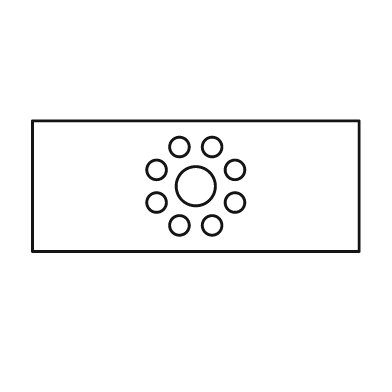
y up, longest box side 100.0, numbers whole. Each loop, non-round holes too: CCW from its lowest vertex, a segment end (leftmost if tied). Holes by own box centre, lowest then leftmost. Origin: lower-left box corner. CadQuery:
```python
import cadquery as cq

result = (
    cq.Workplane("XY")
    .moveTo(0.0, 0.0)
    .lineTo(100.0, 0.0)
    .lineTo(100.0, 40.0)
    .lineTo(0.0, 40.0)
    .close()
    .moveTo(45.0, 8.0)
    .circle(3.0)
    .moveTo(55.0, 8.0)
    .circle(3.0)
    .moveTo(38.0, 15.0)
    .circle(3.0)
    .moveTo(62.0, 15.0)
    .circle(3.0)
    .moveTo(50.0, 20.0)
    .circle(6.0)
    .moveTo(38.0, 25.0)
    .circle(3.0)
    .moveTo(62.0, 25.0)
    .circle(3.0)
    .moveTo(45.0, 32.0)
    .circle(3.0)
    .moveTo(55.0, 32.0)
    .circle(3.0)
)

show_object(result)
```